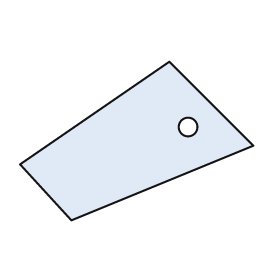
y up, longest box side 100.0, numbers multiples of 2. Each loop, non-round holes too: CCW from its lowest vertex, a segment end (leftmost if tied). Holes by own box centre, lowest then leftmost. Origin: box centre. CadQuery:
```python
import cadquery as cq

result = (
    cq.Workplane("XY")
    .moveTo(-28.0, -34.0)
    .lineTo(50.0, -2.0)
    .lineTo(14.0, 34.0)
    .lineTo(-50.0, -10.0)
    .close()
    .moveTo(22.0, 6.0)
    .circle(4.0)
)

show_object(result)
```